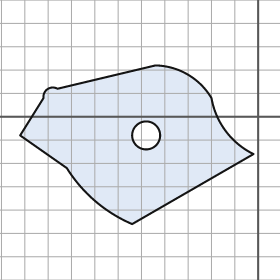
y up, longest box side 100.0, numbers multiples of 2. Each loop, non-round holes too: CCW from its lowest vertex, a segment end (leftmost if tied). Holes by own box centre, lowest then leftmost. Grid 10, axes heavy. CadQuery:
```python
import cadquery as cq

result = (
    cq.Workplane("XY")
    .moveTo(-54.0, -46.0)
    .lineTo(-2.0, -16.0)
    .threePointArc((-14.0, -6.0), (-20.0, 8.0))
    .threePointArc((-30.0, 18.0), (-44.0, 22.0))
    .lineTo(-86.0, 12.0)
    .threePointArc((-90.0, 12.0), (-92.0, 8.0))
    .lineTo(-102.0, -8.0)
    .lineTo(-82.0, -22.0)
    .threePointArc((-70.0, -36.0), (-54.0, -46.0))
    .close()
    .moveTo(-48.0, -8.0)
    .circle(6.0)
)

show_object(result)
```